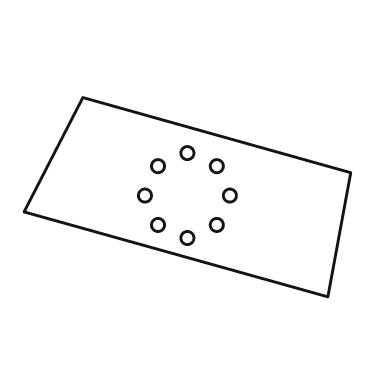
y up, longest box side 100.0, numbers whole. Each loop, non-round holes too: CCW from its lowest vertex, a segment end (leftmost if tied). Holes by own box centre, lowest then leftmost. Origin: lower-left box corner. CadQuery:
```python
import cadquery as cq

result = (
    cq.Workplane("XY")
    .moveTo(93.0, 0.0)
    .lineTo(100.0, 38.0)
    .lineTo(18.0, 61.0)
    .lineTo(0.0, 26.0)
    .close()
    .moveTo(50.0, 18.0)
    .circle(2.0)
    .moveTo(41.0, 22.0)
    .circle(2.0)
    .moveTo(59.0, 22.0)
    .circle(2.0)
    .moveTo(37.0, 31.0)
    .circle(2.0)
    .moveTo(63.0, 31.0)
    .circle(2.0)
    .moveTo(41.0, 40.0)
    .circle(2.0)
    .moveTo(59.0, 40.0)
    .circle(2.0)
    .moveTo(50.0, 44.0)
    .circle(2.0)
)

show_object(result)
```